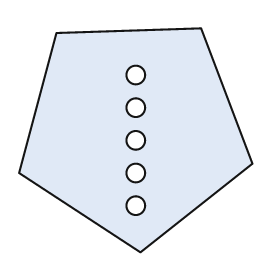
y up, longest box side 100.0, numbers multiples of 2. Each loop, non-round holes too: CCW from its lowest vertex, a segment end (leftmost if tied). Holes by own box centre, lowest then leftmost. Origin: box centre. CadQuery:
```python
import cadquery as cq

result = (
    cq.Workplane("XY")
    .moveTo(2.0, -48.0)
    .lineTo(50.0, -10.0)
    .lineTo(28.0, 48.0)
    .lineTo(-34.0, 46.0)
    .lineTo(-50.0, -14.0)
    .close()
    .moveTo(0.0, -28.0)
    .circle(4.0)
    .moveTo(0.0, -14.0)
    .circle(4.0)
    .moveTo(0.0, 0.0)
    .circle(4.0)
    .moveTo(0.0, 14.0)
    .circle(4.0)
    .moveTo(0.0, 28.0)
    .circle(4.0)
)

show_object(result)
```